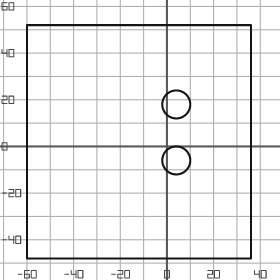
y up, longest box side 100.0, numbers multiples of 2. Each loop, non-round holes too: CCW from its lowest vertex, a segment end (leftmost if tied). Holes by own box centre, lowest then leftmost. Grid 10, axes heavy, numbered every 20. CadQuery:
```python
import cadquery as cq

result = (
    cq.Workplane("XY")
    .moveTo(-60.0, -48.0)
    .lineTo(36.0, -48.0)
    .lineTo(36.0, 52.0)
    .lineTo(-60.0, 52.0)
    .close()
    .moveTo(4.0, -6.0)
    .circle(6.0)
    .moveTo(4.0, 18.0)
    .circle(6.0)
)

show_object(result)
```